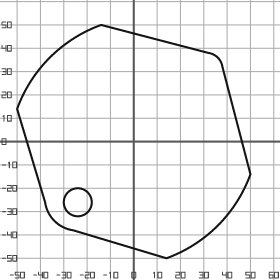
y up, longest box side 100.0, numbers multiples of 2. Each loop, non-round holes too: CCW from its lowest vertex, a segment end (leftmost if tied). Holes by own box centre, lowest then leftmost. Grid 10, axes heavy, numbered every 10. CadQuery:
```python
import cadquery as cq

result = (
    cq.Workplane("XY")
    .moveTo(14.0, -50.0)
    .threePointArc((36.0, -36.0), (50.0, -14.0))
    .lineTo(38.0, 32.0)
    .threePointArc((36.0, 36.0), (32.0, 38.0))
    .lineTo(-14.0, 50.0)
    .threePointArc((-36.0, 36.0), (-50.0, 14.0))
    .lineTo(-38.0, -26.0)
    .threePointArc((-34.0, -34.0), (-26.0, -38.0))
    .close()
    .moveTo(-24.0, -26.0)
    .circle(6.0)
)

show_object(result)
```